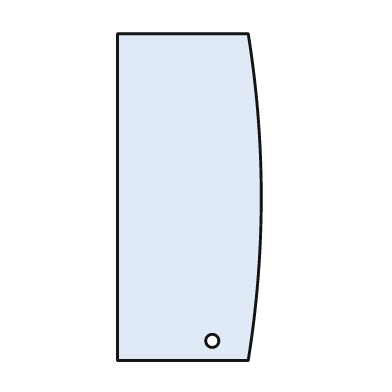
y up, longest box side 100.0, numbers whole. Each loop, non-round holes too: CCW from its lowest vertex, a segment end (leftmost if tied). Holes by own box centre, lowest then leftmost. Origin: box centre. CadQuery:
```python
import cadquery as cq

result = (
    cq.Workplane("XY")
    .moveTo(-22.0, -50.0)
    .lineTo(18.0, -50.0)
    .threePointArc((22.0, 0.0), (18.0, 50.0))
    .lineTo(-22.0, 50.0)
    .close()
    .moveTo(7.0, -44.0)
    .circle(2.0)
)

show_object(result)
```